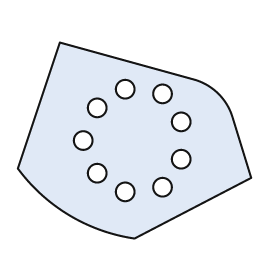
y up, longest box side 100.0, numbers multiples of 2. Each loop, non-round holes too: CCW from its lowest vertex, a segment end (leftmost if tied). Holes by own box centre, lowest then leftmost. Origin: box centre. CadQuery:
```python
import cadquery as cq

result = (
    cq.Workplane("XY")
    .moveTo(0.0, -42.0)
    .lineTo(50.0, -16.0)
    .lineTo(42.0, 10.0)
    .threePointArc((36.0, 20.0), (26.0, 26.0))
    .lineTo(-32.0, 42.0)
    .lineTo(-50.0, -12.0)
    .threePointArc((-28.0, -32.0), (0.0, -42.0))
    .close()
    .moveTo(-4.0, -22.0)
    .circle(4.0)
    .moveTo(12.0, -20.0)
    .circle(4.0)
    .moveTo(-16.0, -14.0)
    .circle(4.0)
    .moveTo(20.0, -8.0)
    .circle(4.0)
    .moveTo(-22.0, 0.0)
    .circle(4.0)
    .moveTo(20.0, 8.0)
    .circle(4.0)
    .moveTo(-16.0, 14.0)
    .circle(4.0)
    .moveTo(12.0, 20.0)
    .circle(4.0)
    .moveTo(-4.0, 22.0)
    .circle(4.0)
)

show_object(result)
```